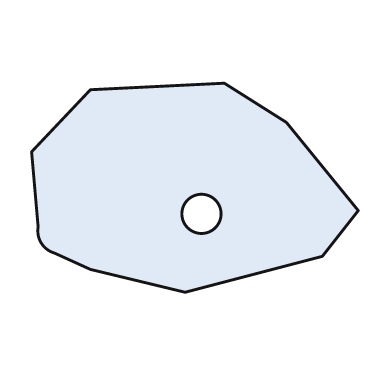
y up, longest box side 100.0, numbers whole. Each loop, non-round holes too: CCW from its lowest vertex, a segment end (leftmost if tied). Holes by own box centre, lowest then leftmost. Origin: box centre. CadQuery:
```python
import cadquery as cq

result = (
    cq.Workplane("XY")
    .moveTo(-3.0, -32.0)
    .lineTo(39.0, -21.0)
    .lineTo(50.0, -7.0)
    .lineTo(28.0, 20.0)
    .lineTo(9.0, 32.0)
    .lineTo(-32.0, 30.0)
    .lineTo(-50.0, 11.0)
    .lineTo(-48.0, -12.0)
    .threePointArc((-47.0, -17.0), (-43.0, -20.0))
    .lineTo(-32.0, -25.0)
    .close()
    .moveTo(2.0, -8.0)
    .circle(6.0)
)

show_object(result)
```